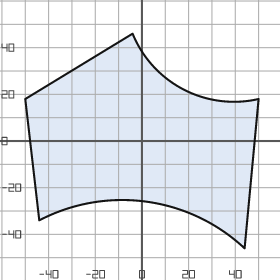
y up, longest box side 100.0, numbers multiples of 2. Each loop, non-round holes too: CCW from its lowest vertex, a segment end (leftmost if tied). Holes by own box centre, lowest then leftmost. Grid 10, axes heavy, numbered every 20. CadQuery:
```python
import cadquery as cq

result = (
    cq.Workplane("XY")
    .moveTo(44.0, -46.0)
    .lineTo(50.0, 18.0)
    .threePointArc((18.0, 22.0), (-4.0, 46.0))
    .lineTo(-50.0, 18.0)
    .lineTo(-44.0, -34.0)
    .threePointArc((2.0, -26.0), (44.0, -46.0))
    .close()
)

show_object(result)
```